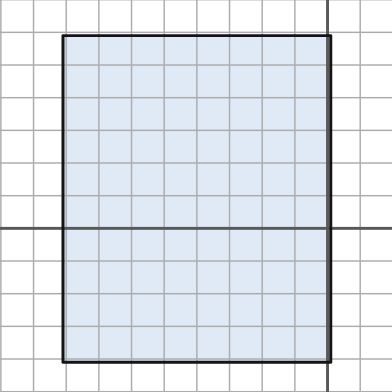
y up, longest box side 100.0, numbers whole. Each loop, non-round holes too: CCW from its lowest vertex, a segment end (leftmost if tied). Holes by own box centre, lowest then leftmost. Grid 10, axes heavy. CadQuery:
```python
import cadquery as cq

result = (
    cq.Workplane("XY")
    .moveTo(-81.0, -41.0)
    .lineTo(1.0, -41.0)
    .lineTo(1.0, 59.0)
    .lineTo(-81.0, 59.0)
    .close()
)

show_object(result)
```